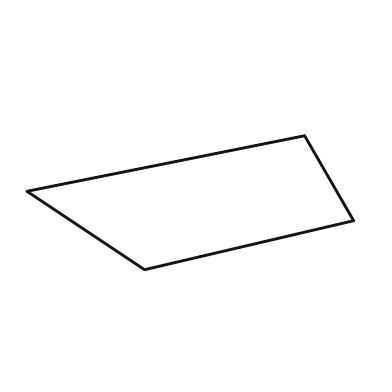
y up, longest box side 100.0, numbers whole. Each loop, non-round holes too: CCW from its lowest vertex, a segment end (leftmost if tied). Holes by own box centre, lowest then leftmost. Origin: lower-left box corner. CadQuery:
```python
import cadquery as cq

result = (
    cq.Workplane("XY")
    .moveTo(36.0, 0.0)
    .lineTo(100.0, 15.0)
    .lineTo(85.0, 41.0)
    .lineTo(0.0, 24.0)
    .close()
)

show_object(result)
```